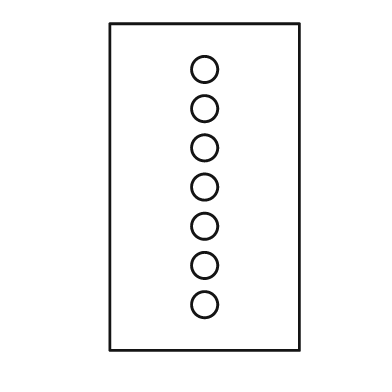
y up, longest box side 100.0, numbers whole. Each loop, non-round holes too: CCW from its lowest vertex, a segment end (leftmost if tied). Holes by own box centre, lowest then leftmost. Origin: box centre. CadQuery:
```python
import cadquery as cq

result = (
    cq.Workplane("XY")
    .moveTo(-29.0, -50.0)
    .lineTo(29.0, -50.0)
    .lineTo(29.0, 50.0)
    .lineTo(-29.0, 50.0)
    .close()
    .moveTo(0.0, -36.0)
    .circle(4.0)
    .moveTo(0.0, -24.0)
    .circle(4.0)
    .moveTo(0.0, -12.0)
    .circle(4.0)
    .moveTo(0.0, 0.0)
    .circle(4.0)
    .moveTo(0.0, 12.0)
    .circle(4.0)
    .moveTo(0.0, 24.0)
    .circle(4.0)
    .moveTo(0.0, 36.0)
    .circle(4.0)
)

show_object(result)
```